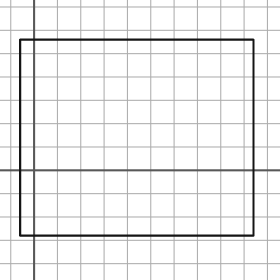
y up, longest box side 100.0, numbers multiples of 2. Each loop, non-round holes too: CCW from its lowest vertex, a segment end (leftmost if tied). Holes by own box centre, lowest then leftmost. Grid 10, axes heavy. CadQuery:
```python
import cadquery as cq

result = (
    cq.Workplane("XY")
    .moveTo(-6.0, -28.0)
    .lineTo(94.0, -28.0)
    .lineTo(94.0, 56.0)
    .lineTo(-6.0, 56.0)
    .close()
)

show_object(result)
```